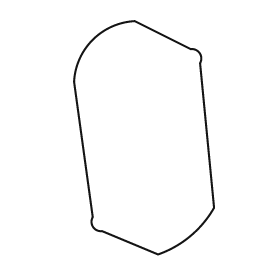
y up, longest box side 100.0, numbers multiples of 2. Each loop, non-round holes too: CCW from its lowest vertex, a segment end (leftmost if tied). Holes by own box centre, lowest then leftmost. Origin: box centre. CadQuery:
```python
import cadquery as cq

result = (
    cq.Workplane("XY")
    .moveTo(6.0, -50.0)
    .threePointArc((20.0, -42.0), (30.0, -30.0))
    .lineTo(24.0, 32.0)
    .threePointArc((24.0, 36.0), (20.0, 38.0))
    .lineTo(-4.0, 50.0)
    .threePointArc((-22.0, 42.0), (-30.0, 24.0))
    .lineTo(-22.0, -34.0)
    .threePointArc((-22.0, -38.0), (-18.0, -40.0))
    .close()
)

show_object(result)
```